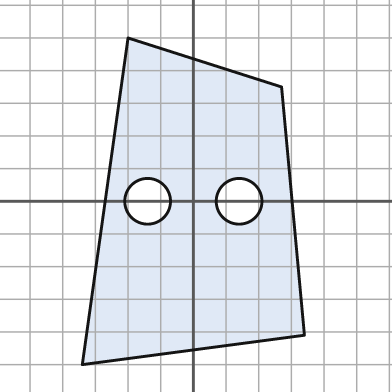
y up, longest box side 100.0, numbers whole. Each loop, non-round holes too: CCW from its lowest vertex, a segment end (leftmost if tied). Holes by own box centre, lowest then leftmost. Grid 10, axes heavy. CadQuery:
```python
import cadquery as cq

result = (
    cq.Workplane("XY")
    .moveTo(-34.0, -50.0)
    .lineTo(34.0, -41.0)
    .lineTo(27.0, 35.0)
    .lineTo(-20.0, 50.0)
    .close()
    .moveTo(-14.0, 0.0)
    .circle(7.0)
    .moveTo(14.0, 0.0)
    .circle(7.0)
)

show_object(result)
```